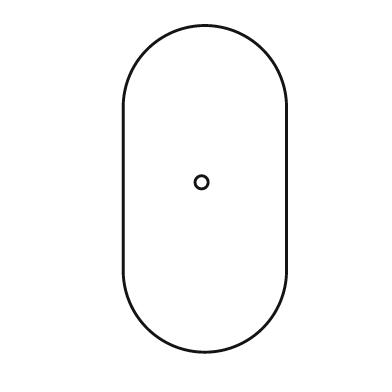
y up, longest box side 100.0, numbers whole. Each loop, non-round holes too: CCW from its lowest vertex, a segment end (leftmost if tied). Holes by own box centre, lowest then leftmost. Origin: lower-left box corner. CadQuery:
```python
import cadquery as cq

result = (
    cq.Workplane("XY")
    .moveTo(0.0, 25.0)
    .threePointArc((25.0, 0.0), (50.0, 25.0))
    .lineTo(50.0, 75.0)
    .threePointArc((25.0, 100.0), (0.0, 75.0))
    .close()
    .moveTo(24.0, 52.0)
    .circle(2.0)
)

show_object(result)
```